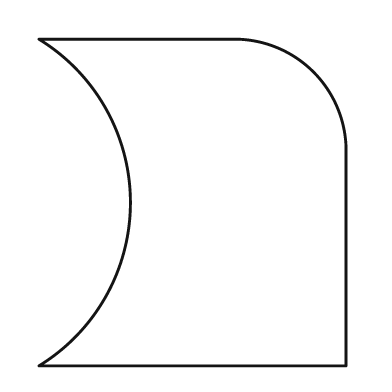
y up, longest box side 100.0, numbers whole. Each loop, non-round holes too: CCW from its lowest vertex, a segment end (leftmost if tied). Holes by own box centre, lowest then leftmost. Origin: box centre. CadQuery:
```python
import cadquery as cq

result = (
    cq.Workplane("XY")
    .moveTo(-47.0, -50.0)
    .lineTo(47.0, -50.0)
    .lineTo(47.0, 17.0)
    .threePointArc((37.0, 40.0), (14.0, 50.0))
    .lineTo(-47.0, 50.0)
    .threePointArc((-19.0, 0.0), (-47.0, -50.0))
    .close()
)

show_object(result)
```